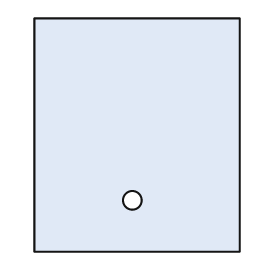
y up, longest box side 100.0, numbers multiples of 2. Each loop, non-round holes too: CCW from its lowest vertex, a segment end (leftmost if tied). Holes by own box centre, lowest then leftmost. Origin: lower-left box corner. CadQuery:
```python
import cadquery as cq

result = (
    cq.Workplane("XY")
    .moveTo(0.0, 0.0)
    .lineTo(88.0, 0.0)
    .lineTo(88.0, 100.0)
    .lineTo(0.0, 100.0)
    .close()
    .moveTo(42.0, 22.0)
    .circle(4.0)
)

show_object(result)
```